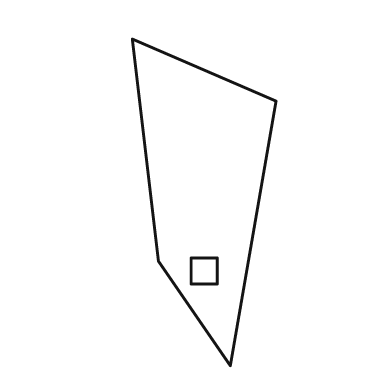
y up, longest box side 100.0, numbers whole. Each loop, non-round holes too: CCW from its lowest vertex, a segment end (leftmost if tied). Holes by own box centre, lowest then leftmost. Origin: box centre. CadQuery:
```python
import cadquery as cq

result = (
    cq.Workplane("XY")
    .moveTo(8.0, -50.0)
    .lineTo(22.0, 31.0)
    .lineTo(-22.0, 50.0)
    .lineTo(-14.0, -18.0)
    .close()
    .moveTo(-4.0, -25.0)
    .lineTo(4.0, -25.0)
    .lineTo(4.0, -17.0)
    .lineTo(-4.0, -17.0)
    .close()
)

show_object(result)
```